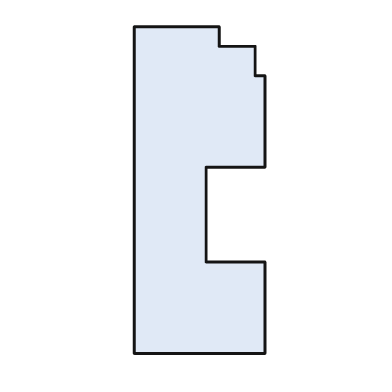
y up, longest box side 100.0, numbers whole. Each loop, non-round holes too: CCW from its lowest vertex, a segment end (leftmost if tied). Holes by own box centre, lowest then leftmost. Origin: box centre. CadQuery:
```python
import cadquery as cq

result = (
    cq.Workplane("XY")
    .moveTo(-20.0, -50.0)
    .lineTo(20.0, -50.0)
    .lineTo(20.0, -22.0)
    .lineTo(2.0, -22.0)
    .lineTo(2.0, 7.0)
    .lineTo(20.0, 7.0)
    .lineTo(20.0, 35.0)
    .lineTo(17.0, 35.0)
    .lineTo(17.0, 44.0)
    .lineTo(6.0, 44.0)
    .lineTo(6.0, 50.0)
    .lineTo(-20.0, 50.0)
    .close()
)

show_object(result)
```